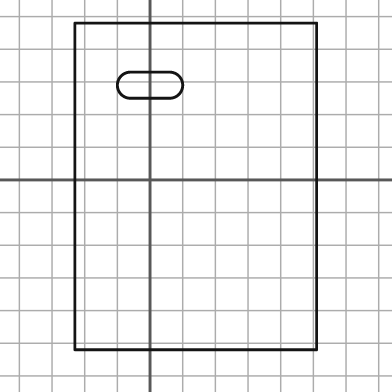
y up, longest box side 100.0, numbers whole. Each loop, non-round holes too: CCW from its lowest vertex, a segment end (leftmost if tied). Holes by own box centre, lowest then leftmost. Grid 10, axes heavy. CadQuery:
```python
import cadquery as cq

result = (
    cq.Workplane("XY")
    .moveTo(-23.0, -52.0)
    .lineTo(51.0, -52.0)
    .lineTo(51.0, 48.0)
    .lineTo(-23.0, 48.0)
    .close()
    .moveTo(-6.0, 25.0)
    .lineTo(6.0, 25.0)
    .threePointArc((10.0, 29.0), (6.0, 33.0))
    .lineTo(-6.0, 33.0)
    .threePointArc((-10.0, 29.0), (-6.0, 25.0))
    .close()
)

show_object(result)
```